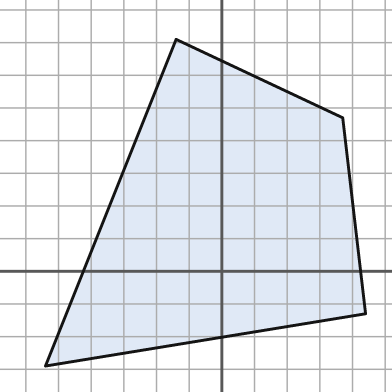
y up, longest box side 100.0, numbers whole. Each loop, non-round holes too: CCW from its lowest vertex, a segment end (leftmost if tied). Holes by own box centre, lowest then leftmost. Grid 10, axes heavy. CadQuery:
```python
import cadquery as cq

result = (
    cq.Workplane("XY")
    .moveTo(-54.0, -29.0)
    .lineTo(44.0, -13.0)
    .lineTo(37.0, 47.0)
    .lineTo(-14.0, 71.0)
    .close()
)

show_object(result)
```